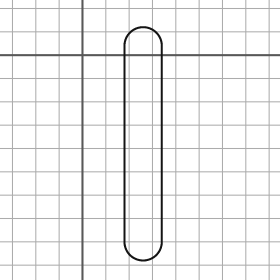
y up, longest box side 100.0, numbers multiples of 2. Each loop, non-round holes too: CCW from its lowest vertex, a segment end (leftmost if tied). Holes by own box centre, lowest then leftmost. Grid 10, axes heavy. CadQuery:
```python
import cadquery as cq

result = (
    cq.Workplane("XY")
    .moveTo(18.0, -80.0)
    .threePointArc((26.0, -88.0), (34.0, -80.0))
    .lineTo(34.0, 4.0)
    .threePointArc((26.0, 12.0), (18.0, 4.0))
    .close()
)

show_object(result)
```